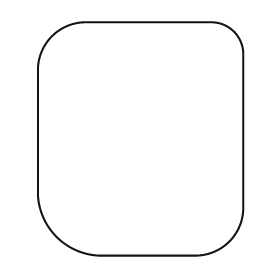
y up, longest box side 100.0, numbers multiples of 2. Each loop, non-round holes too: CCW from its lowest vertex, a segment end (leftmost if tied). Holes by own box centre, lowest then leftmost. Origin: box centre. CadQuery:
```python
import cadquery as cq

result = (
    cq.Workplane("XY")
    .moveTo(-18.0, -50.0)
    .lineTo(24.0, -50.0)
    .threePointArc((38.0, -44.0), (44.0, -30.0))
    .lineTo(44.0, 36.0)
    .threePointArc((40.0, 46.0), (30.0, 50.0))
    .lineTo(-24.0, 50.0)
    .threePointArc((-38.0, 44.0), (-44.0, 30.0))
    .lineTo(-44.0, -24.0)
    .threePointArc((-36.0, -42.0), (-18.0, -50.0))
    .close()
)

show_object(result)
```